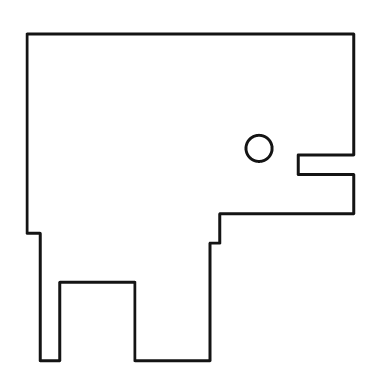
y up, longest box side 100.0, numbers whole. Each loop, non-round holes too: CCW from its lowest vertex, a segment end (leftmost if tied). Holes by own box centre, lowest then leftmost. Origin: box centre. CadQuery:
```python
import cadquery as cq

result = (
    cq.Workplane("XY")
    .moveTo(-46.0, -50.0)
    .lineTo(-40.0, -50.0)
    .lineTo(-40.0, -26.0)
    .lineTo(-17.0, -26.0)
    .lineTo(-17.0, -50.0)
    .lineTo(6.0, -50.0)
    .lineTo(6.0, -14.0)
    .lineTo(9.0, -14.0)
    .lineTo(9.0, -5.0)
    .lineTo(50.0, -5.0)
    .lineTo(50.0, 7.0)
    .lineTo(33.0, 7.0)
    .lineTo(33.0, 13.0)
    .lineTo(50.0, 13.0)
    .lineTo(50.0, 50.0)
    .lineTo(-50.0, 50.0)
    .lineTo(-50.0, -11.0)
    .lineTo(-46.0, -11.0)
    .close()
    .moveTo(21.0, 15.0)
    .circle(4.0)
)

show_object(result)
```